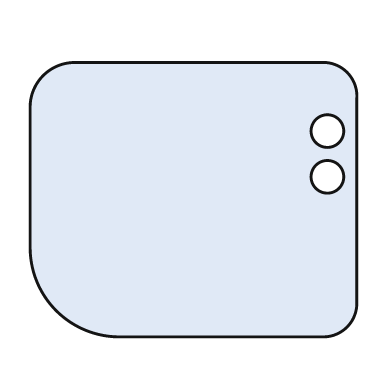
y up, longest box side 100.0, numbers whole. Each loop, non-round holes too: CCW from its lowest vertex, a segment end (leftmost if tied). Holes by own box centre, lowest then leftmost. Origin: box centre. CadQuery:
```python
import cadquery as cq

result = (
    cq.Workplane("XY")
    .moveTo(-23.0, -42.0)
    .lineTo(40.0, -42.0)
    .threePointArc((47.0, -39.0), (50.0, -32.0))
    .lineTo(50.0, 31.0)
    .threePointArc((47.0, 39.0), (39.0, 42.0))
    .lineTo(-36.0, 42.0)
    .threePointArc((-46.0, 38.0), (-50.0, 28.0))
    .lineTo(-50.0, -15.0)
    .threePointArc((-42.0, -34.0), (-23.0, -42.0))
    .close()
    .moveTo(41.0, 7.0)
    .circle(5.0)
    .moveTo(41.0, 21.0)
    .circle(5.0)
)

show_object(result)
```